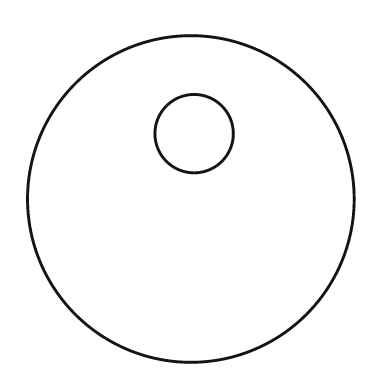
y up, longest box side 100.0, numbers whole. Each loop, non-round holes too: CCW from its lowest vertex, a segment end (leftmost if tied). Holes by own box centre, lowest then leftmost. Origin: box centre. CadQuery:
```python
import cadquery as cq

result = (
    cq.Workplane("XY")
    .moveTo(0.0, 0.0)
    .circle(50.0)
    .moveTo(1.0, 20.0)
    .circle(12.0)
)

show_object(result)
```